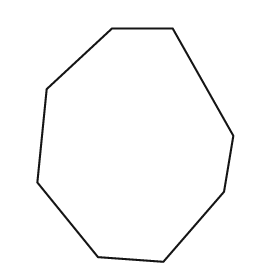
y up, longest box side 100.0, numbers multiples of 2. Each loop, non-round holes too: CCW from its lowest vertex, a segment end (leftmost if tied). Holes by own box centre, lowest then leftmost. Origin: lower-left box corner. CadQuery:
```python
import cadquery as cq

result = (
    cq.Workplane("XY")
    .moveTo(54.0, 0.0)
    .lineTo(80.0, 30.0)
    .lineTo(84.0, 54.0)
    .lineTo(58.0, 100.0)
    .lineTo(32.0, 100.0)
    .lineTo(4.0, 74.0)
    .lineTo(0.0, 34.0)
    .lineTo(26.0, 2.0)
    .close()
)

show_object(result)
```